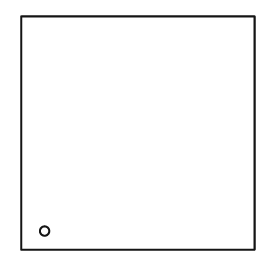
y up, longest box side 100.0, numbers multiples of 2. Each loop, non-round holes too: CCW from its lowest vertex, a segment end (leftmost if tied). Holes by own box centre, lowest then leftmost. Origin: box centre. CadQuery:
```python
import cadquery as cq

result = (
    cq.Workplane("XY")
    .moveTo(-50.0, -50.0)
    .lineTo(50.0, -50.0)
    .lineTo(50.0, 50.0)
    .lineTo(-50.0, 50.0)
    .close()
    .moveTo(-40.0, -42.0)
    .circle(2.0)
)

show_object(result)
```